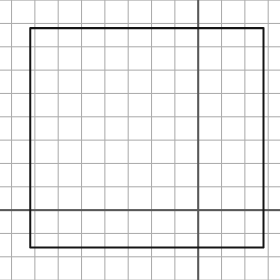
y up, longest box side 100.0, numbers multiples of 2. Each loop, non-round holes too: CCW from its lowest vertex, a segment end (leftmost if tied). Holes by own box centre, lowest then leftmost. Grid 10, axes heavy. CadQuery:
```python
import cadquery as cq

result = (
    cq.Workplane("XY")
    .moveTo(-72.0, -16.0)
    .lineTo(28.0, -16.0)
    .lineTo(28.0, 78.0)
    .lineTo(-72.0, 78.0)
    .close()
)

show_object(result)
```